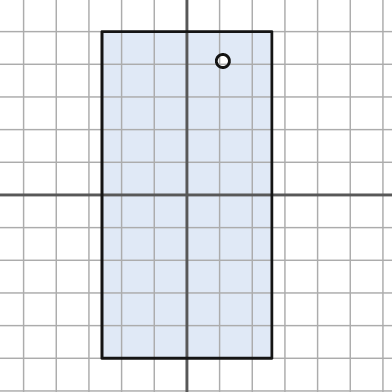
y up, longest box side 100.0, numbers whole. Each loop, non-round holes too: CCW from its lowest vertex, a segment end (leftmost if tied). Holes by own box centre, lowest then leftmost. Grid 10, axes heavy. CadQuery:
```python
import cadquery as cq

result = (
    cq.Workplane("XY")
    .moveTo(-26.0, -50.0)
    .lineTo(26.0, -50.0)
    .lineTo(26.0, 50.0)
    .lineTo(-26.0, 50.0)
    .close()
    .moveTo(11.0, 41.0)
    .circle(2.0)
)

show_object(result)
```